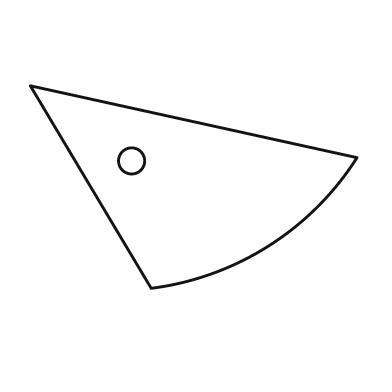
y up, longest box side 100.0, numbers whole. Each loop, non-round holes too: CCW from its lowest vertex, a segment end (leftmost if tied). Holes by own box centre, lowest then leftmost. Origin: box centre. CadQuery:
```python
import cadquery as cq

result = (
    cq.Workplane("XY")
    .moveTo(-13.0, -31.0)
    .threePointArc((23.0, -18.0), (50.0, 9.0))
    .lineTo(-50.0, 31.0)
    .close()
    .moveTo(-19.0, 8.0)
    .circle(4.0)
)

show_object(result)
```